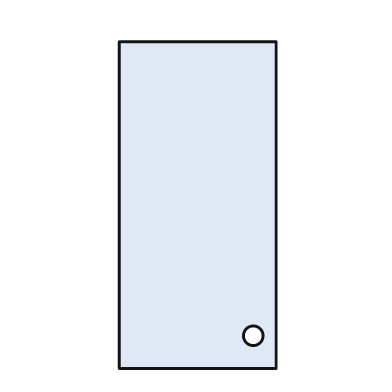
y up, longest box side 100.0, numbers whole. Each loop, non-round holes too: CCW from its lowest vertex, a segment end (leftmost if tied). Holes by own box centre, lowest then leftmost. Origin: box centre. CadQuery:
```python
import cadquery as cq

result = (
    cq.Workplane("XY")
    .moveTo(-24.0, -50.0)
    .lineTo(24.0, -50.0)
    .lineTo(24.0, 50.0)
    .lineTo(-24.0, 50.0)
    .close()
    .moveTo(17.0, -40.0)
    .circle(3.0)
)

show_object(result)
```